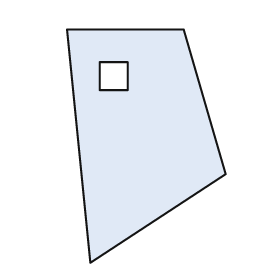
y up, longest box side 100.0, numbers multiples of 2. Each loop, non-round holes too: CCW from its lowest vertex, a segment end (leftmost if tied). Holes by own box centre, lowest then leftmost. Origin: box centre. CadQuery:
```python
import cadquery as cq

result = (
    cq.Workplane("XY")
    .moveTo(-24.0, -50.0)
    .lineTo(34.0, -12.0)
    .lineTo(16.0, 50.0)
    .lineTo(-34.0, 50.0)
    .close()
    .moveTo(-20.0, 24.0)
    .lineTo(-8.0, 24.0)
    .lineTo(-8.0, 36.0)
    .lineTo(-20.0, 36.0)
    .close()
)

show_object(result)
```